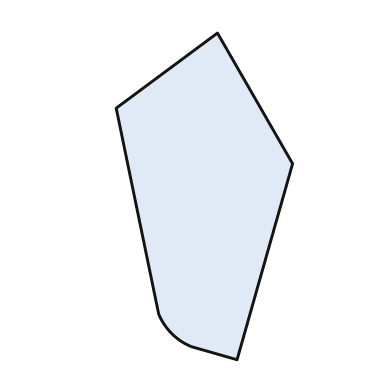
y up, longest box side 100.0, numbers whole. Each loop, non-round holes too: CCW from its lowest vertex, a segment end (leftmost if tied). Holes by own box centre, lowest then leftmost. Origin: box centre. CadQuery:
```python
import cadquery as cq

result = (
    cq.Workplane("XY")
    .moveTo(10.0, -50.0)
    .lineTo(27.0, 10.0)
    .lineTo(4.0, 50.0)
    .lineTo(-27.0, 27.0)
    .lineTo(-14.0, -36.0)
    .threePointArc((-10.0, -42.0), (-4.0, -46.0))
    .close()
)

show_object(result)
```